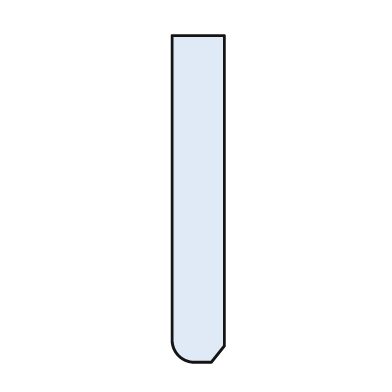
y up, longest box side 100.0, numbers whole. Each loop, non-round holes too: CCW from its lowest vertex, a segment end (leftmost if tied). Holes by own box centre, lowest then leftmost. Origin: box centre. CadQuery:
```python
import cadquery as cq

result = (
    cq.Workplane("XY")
    .moveTo(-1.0, -50.0)
    .lineTo(4.0, -50.0)
    .lineTo(8.0, -45.0)
    .lineTo(8.0, 50.0)
    .lineTo(-8.0, 50.0)
    .lineTo(-8.0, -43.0)
    .threePointArc((-6.0, -48.0), (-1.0, -50.0))
    .close()
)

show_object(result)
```